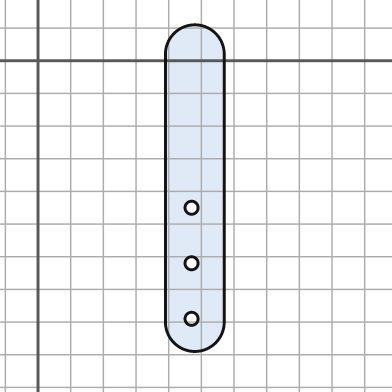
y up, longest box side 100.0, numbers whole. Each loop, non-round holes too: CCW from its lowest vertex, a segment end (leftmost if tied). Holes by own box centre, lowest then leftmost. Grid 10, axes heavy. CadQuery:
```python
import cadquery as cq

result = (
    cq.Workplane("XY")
    .moveTo(39.0, -80.0)
    .threePointArc((48.0, -89.0), (57.0, -80.0))
    .lineTo(57.0, 2.0)
    .threePointArc((48.0, 11.0), (39.0, 2.0))
    .close()
    .moveTo(47.0, -79.0)
    .circle(2.0)
    .moveTo(47.0, -62.0)
    .circle(2.0)
    .moveTo(47.0, -45.0)
    .circle(2.0)
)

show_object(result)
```